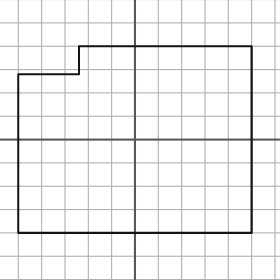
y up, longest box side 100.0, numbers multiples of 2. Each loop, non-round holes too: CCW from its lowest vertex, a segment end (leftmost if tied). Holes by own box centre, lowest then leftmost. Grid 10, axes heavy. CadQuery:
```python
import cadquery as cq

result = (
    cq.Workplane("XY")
    .moveTo(-50.0, -40.0)
    .lineTo(50.0, -40.0)
    .lineTo(50.0, 40.0)
    .lineTo(-24.0, 40.0)
    .lineTo(-24.0, 28.0)
    .lineTo(-50.0, 28.0)
    .close()
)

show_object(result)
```